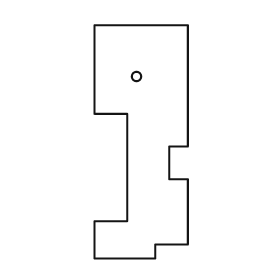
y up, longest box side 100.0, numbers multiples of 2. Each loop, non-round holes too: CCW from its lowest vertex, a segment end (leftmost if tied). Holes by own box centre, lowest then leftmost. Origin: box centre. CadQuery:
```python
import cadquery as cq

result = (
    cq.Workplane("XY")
    .moveTo(-20.0, -50.0)
    .lineTo(6.0, -50.0)
    .lineTo(6.0, -44.0)
    .lineTo(20.0, -44.0)
    .lineTo(20.0, -16.0)
    .lineTo(12.0, -16.0)
    .lineTo(12.0, -2.0)
    .lineTo(20.0, -2.0)
    .lineTo(20.0, 50.0)
    .lineTo(-20.0, 50.0)
    .lineTo(-20.0, 12.0)
    .lineTo(-6.0, 12.0)
    .lineTo(-6.0, -34.0)
    .lineTo(-20.0, -34.0)
    .close()
    .moveTo(-2.0, 28.0)
    .circle(2.0)
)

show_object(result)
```